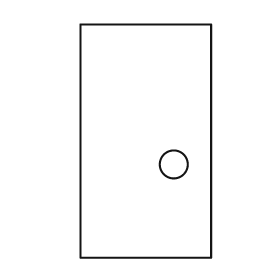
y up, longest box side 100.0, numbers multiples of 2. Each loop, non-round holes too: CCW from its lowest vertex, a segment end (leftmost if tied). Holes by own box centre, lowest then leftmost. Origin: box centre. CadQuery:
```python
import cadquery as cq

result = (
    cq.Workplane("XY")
    .moveTo(-28.0, -50.0)
    .lineTo(28.0, -50.0)
    .lineTo(28.0, 50.0)
    .lineTo(-28.0, 50.0)
    .close()
    .moveTo(12.0, -10.0)
    .circle(6.0)
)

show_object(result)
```